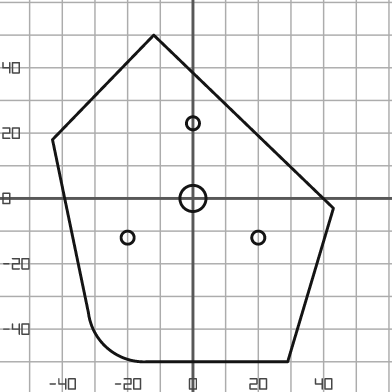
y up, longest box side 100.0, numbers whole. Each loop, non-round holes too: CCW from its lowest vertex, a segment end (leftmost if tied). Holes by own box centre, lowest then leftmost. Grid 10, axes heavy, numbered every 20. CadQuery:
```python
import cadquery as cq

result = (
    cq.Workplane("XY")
    .moveTo(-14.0, -50.0)
    .lineTo(29.0, -50.0)
    .lineTo(43.0, -3.0)
    .lineTo(-12.0, 50.0)
    .lineTo(-43.0, 18.0)
    .lineTo(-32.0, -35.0)
    .threePointArc((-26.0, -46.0), (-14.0, -50.0))
    .close()
    .moveTo(-20.0, -12.0)
    .circle(2.0)
    .moveTo(20.0, -12.0)
    .circle(2.0)
    .moveTo(0.0, 0.0)
    .circle(4.0)
    .moveTo(0.0, 23.0)
    .circle(2.0)
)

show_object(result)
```